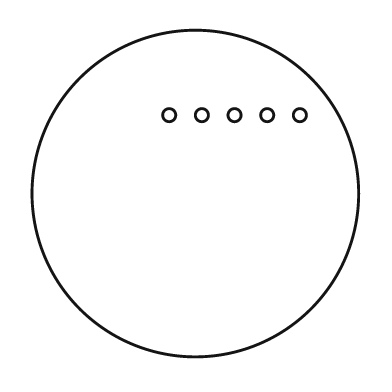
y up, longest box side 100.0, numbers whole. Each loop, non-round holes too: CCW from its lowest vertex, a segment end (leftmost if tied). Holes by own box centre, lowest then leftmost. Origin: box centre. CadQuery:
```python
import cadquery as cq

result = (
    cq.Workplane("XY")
    .moveTo(0.0, 0.0)
    .circle(50.0)
    .moveTo(-8.0, 24.0)
    .circle(2.0)
    .moveTo(2.0, 24.0)
    .circle(2.0)
    .moveTo(12.0, 24.0)
    .circle(2.0)
    .moveTo(22.0, 24.0)
    .circle(2.0)
    .moveTo(32.0, 24.0)
    .circle(2.0)
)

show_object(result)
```